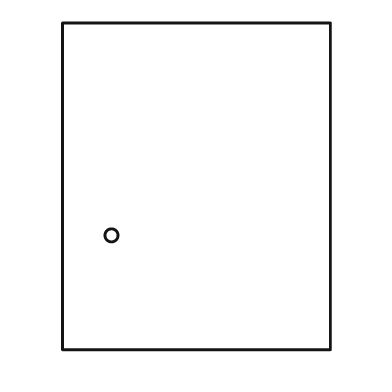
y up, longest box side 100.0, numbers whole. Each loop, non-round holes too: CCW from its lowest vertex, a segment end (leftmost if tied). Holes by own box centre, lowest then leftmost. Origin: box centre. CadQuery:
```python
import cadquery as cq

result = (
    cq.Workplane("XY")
    .moveTo(-41.0, -50.0)
    .lineTo(41.0, -50.0)
    .lineTo(41.0, 50.0)
    .lineTo(-41.0, 50.0)
    .close()
    .moveTo(-26.0, -15.0)
    .circle(2.0)
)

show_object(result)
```